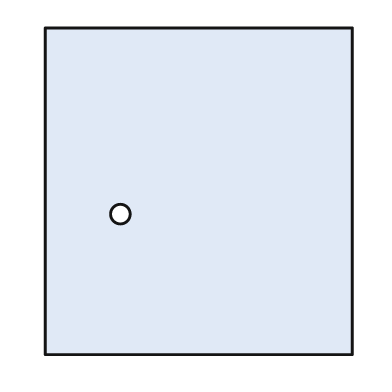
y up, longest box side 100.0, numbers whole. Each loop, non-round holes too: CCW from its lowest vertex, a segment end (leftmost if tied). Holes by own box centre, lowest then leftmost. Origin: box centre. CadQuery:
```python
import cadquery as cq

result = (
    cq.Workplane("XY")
    .moveTo(-47.0, -50.0)
    .lineTo(47.0, -50.0)
    .lineTo(47.0, 50.0)
    .lineTo(-47.0, 50.0)
    .close()
    .moveTo(-24.0, -7.0)
    .circle(3.0)
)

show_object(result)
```